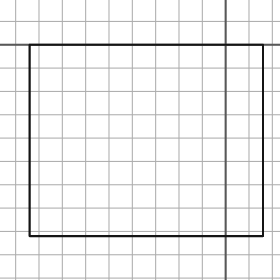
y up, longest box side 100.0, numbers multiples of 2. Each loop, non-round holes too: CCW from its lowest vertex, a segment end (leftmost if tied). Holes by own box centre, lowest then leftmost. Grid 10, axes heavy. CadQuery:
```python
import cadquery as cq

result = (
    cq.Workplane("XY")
    .moveTo(-84.0, -82.0)
    .lineTo(16.0, -82.0)
    .lineTo(16.0, 0.0)
    .lineTo(-84.0, 0.0)
    .close()
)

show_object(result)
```